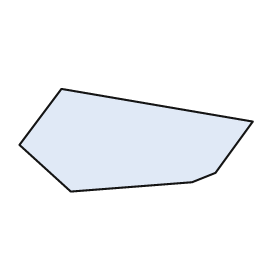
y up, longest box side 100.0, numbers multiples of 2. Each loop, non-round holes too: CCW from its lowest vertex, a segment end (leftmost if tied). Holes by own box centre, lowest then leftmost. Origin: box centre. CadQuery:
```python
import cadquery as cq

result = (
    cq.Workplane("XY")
    .moveTo(-28.0, -22.0)
    .lineTo(24.0, -18.0)
    .lineTo(34.0, -14.0)
    .lineTo(50.0, 8.0)
    .lineTo(-32.0, 22.0)
    .lineTo(-50.0, -2.0)
    .close()
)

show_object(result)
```